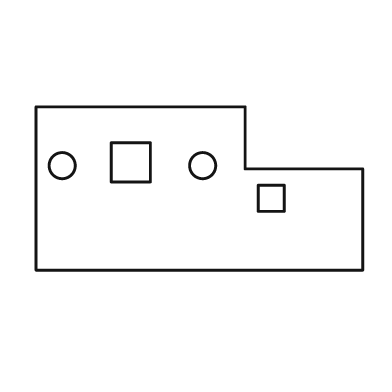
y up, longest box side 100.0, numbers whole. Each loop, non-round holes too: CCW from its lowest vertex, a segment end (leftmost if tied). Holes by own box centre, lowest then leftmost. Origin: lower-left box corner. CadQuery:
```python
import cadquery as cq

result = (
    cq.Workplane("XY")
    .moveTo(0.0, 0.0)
    .lineTo(100.0, 0.0)
    .lineTo(100.0, 31.0)
    .lineTo(64.0, 31.0)
    .lineTo(64.0, 50.0)
    .lineTo(0.0, 50.0)
    .close()
    .moveTo(68.0, 18.0)
    .lineTo(76.0, 18.0)
    .lineTo(76.0, 26.0)
    .lineTo(68.0, 26.0)
    .close()
    .moveTo(8.0, 32.0)
    .circle(4.0)
    .moveTo(51.0, 32.0)
    .circle(4.0)
    .moveTo(23.0, 27.0)
    .lineTo(35.0, 27.0)
    .lineTo(35.0, 39.0)
    .lineTo(23.0, 39.0)
    .close()
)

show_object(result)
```